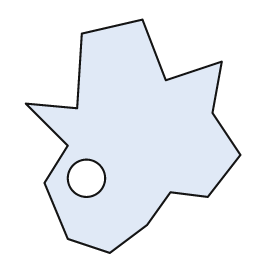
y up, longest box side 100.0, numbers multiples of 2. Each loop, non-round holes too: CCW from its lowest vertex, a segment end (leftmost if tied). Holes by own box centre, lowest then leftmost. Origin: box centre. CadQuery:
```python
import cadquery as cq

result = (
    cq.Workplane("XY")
    .moveTo(-10.0, -50.0)
    .lineTo(6.0, -38.0)
    .lineTo(16.0, -24.0)
    .lineTo(32.0, -26.0)
    .lineTo(46.0, -8.0)
    .lineTo(34.0, 10.0)
    .lineTo(38.0, 32.0)
    .lineTo(14.0, 24.0)
    .lineTo(4.0, 50.0)
    .lineTo(-22.0, 44.0)
    .lineTo(-24.0, 12.0)
    .lineTo(-46.0, 14.0)
    .lineTo(-28.0, -4.0)
    .lineTo(-38.0, -20.0)
    .lineTo(-28.0, -44.0)
    .close()
    .moveTo(-20.0, -18.0)
    .circle(8.0)
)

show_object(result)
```